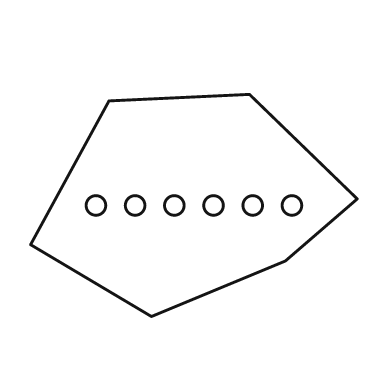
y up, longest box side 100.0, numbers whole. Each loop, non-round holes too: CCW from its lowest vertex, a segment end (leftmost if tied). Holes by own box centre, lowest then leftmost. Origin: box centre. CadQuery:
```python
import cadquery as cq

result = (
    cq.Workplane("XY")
    .moveTo(-13.0, -34.0)
    .lineTo(28.0, -17.0)
    .lineTo(50.0, 2.0)
    .lineTo(17.0, 34.0)
    .lineTo(-26.0, 32.0)
    .lineTo(-50.0, -12.0)
    .close()
    .moveTo(-30.0, 0.0)
    .circle(3.0)
    .moveTo(-18.0, 0.0)
    .circle(3.0)
    .moveTo(-6.0, 0.0)
    .circle(3.0)
    .moveTo(6.0, 0.0)
    .circle(3.0)
    .moveTo(18.0, 0.0)
    .circle(3.0)
    .moveTo(30.0, 0.0)
    .circle(3.0)
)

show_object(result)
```